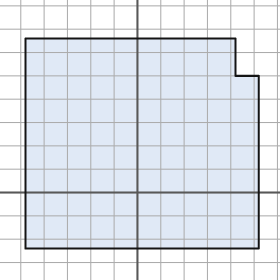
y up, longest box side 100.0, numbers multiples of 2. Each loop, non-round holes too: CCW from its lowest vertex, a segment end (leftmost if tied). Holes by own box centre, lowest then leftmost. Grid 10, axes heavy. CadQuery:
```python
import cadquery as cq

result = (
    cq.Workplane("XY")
    .moveTo(-48.0, -24.0)
    .lineTo(52.0, -24.0)
    .lineTo(52.0, 50.0)
    .lineTo(42.0, 50.0)
    .lineTo(42.0, 66.0)
    .lineTo(-48.0, 66.0)
    .close()
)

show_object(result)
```